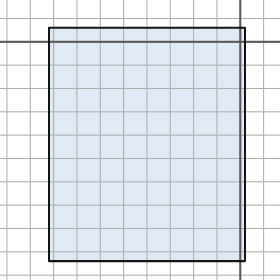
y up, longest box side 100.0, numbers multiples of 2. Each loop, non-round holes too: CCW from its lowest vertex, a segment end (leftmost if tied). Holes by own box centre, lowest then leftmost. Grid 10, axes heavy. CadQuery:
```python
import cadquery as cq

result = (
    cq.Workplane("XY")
    .moveTo(-82.0, -94.0)
    .lineTo(2.0, -94.0)
    .lineTo(2.0, 6.0)
    .lineTo(-82.0, 6.0)
    .close()
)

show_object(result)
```